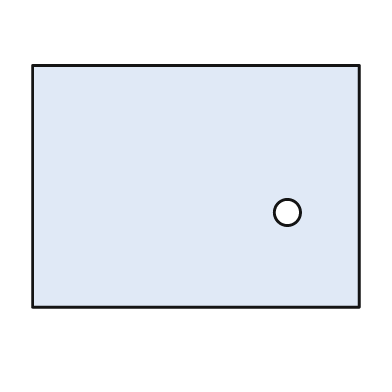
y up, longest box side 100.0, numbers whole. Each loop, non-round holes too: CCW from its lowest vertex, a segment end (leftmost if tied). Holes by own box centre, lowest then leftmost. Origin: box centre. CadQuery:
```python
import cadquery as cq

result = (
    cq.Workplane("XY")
    .moveTo(-50.0, -37.0)
    .lineTo(50.0, -37.0)
    .lineTo(50.0, 37.0)
    .lineTo(-50.0, 37.0)
    .close()
    .moveTo(28.0, -8.0)
    .circle(4.0)
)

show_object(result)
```